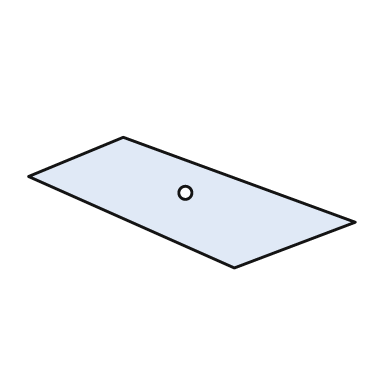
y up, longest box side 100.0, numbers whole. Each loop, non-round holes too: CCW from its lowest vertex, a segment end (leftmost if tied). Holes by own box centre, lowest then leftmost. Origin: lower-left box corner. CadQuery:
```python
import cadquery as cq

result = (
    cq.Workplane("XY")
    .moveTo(63.0, 0.0)
    .lineTo(100.0, 14.0)
    .lineTo(29.0, 40.0)
    .lineTo(0.0, 28.0)
    .close()
    .moveTo(48.0, 23.0)
    .circle(2.0)
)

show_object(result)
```